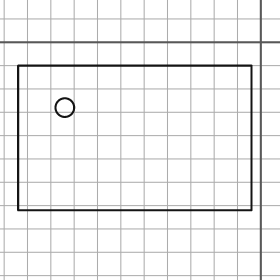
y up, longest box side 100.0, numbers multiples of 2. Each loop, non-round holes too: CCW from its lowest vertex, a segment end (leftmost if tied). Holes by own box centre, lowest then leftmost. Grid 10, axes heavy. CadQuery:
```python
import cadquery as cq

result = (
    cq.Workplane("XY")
    .moveTo(-104.0, -72.0)
    .lineTo(-4.0, -72.0)
    .lineTo(-4.0, -10.0)
    .lineTo(-104.0, -10.0)
    .close()
    .moveTo(-84.0, -28.0)
    .circle(4.0)
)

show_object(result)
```